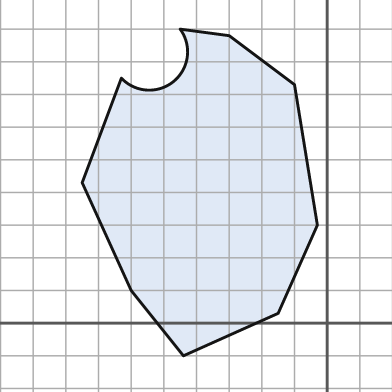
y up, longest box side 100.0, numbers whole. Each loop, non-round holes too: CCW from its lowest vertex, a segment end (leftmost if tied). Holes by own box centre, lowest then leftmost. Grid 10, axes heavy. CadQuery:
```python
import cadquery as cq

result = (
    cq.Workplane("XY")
    .moveTo(-44.0, -10.0)
    .lineTo(-15.0, 3.0)
    .lineTo(-3.0, 30.0)
    .lineTo(-10.0, 73.0)
    .lineTo(-30.0, 88.0)
    .lineTo(-45.0, 90.0)
    .threePointArc((-47.0, 74.0), (-63.0, 75.0))
    .lineTo(-75.0, 43.0)
    .lineTo(-60.0, 10.0)
    .close()
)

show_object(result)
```